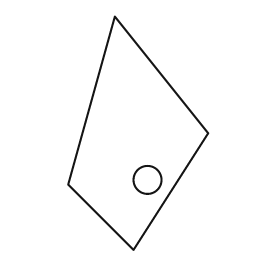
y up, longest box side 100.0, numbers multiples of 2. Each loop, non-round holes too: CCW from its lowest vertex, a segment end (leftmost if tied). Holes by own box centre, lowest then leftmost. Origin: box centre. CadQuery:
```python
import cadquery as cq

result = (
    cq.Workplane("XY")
    .moveTo(-2.0, -50.0)
    .lineTo(30.0, 0.0)
    .lineTo(-10.0, 50.0)
    .lineTo(-30.0, -22.0)
    .close()
    .moveTo(4.0, -20.0)
    .circle(6.0)
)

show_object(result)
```